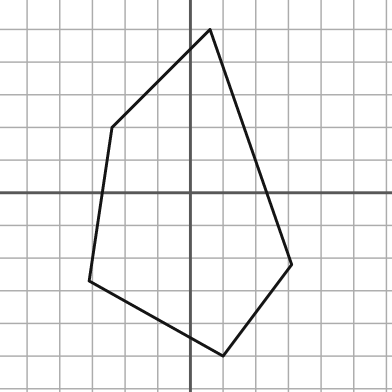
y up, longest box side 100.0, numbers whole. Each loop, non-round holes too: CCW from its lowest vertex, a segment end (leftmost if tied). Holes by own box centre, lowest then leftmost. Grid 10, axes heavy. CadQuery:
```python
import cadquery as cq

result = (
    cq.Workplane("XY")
    .moveTo(10.0, -50.0)
    .lineTo(31.0, -22.0)
    .lineTo(6.0, 50.0)
    .lineTo(-24.0, 20.0)
    .lineTo(-31.0, -27.0)
    .close()
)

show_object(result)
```